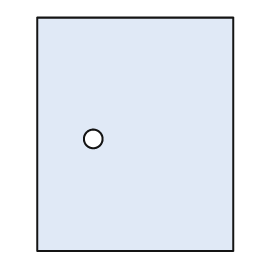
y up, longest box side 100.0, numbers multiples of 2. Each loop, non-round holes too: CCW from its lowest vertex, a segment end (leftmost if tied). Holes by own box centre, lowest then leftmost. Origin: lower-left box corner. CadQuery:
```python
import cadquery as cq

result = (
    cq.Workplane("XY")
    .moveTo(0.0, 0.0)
    .lineTo(84.0, 0.0)
    .lineTo(84.0, 100.0)
    .lineTo(0.0, 100.0)
    .close()
    .moveTo(24.0, 48.0)
    .circle(4.0)
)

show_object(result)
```